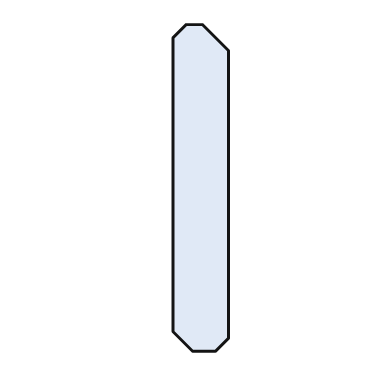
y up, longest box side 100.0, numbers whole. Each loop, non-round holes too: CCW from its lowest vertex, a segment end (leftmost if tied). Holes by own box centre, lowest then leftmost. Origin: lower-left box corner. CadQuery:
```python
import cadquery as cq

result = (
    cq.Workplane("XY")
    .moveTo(6.0, 0.0)
    .lineTo(13.0, 0.0)
    .lineTo(17.0, 4.0)
    .lineTo(17.0, 92.0)
    .lineTo(9.0, 100.0)
    .lineTo(4.0, 100.0)
    .lineTo(0.0, 96.0)
    .lineTo(0.0, 6.0)
    .close()
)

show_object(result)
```